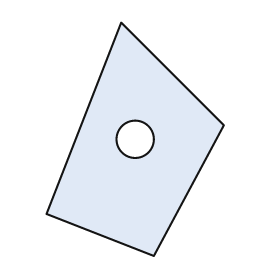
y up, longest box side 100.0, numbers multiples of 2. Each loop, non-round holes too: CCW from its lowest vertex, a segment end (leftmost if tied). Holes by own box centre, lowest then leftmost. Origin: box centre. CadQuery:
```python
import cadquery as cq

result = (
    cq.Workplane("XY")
    .moveTo(8.0, -50.0)
    .lineTo(38.0, 6.0)
    .lineTo(-6.0, 50.0)
    .lineTo(-38.0, -32.0)
    .close()
    .moveTo(0.0, 0.0)
    .circle(8.0)
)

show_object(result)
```